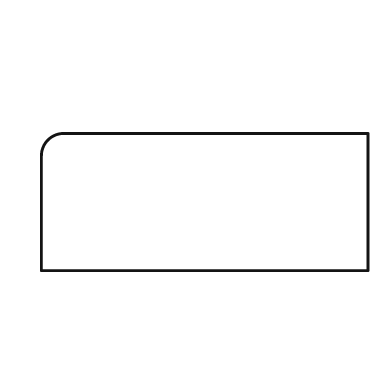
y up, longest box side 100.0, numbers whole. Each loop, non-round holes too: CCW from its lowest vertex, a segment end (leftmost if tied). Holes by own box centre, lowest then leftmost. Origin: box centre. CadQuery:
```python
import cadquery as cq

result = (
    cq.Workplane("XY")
    .moveTo(-50.0, -21.0)
    .lineTo(50.0, -21.0)
    .lineTo(50.0, 21.0)
    .lineTo(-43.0, 21.0)
    .threePointArc((-48.0, 19.0), (-50.0, 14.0))
    .close()
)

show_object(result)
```